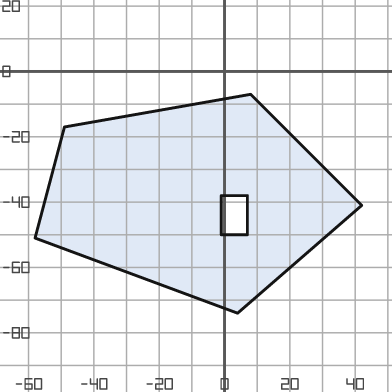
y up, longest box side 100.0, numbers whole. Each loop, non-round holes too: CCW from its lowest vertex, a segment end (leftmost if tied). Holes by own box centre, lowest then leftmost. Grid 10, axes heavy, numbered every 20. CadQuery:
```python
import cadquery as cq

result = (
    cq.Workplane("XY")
    .moveTo(4.0, -74.0)
    .lineTo(42.0, -41.0)
    .lineTo(8.0, -7.0)
    .lineTo(-49.0, -17.0)
    .lineTo(-58.0, -51.0)
    .close()
    .moveTo(-1.0, -50.0)
    .lineTo(7.0, -50.0)
    .lineTo(7.0, -38.0)
    .lineTo(-1.0, -38.0)
    .close()
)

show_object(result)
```